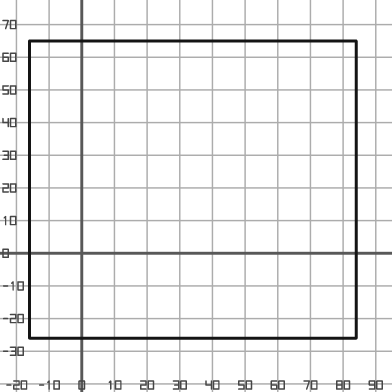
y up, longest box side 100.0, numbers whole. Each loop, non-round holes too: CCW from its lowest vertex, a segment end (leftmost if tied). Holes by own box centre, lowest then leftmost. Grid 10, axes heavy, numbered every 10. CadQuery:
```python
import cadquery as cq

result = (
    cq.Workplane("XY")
    .moveTo(-16.0, -26.0)
    .lineTo(84.0, -26.0)
    .lineTo(84.0, 65.0)
    .lineTo(-16.0, 65.0)
    .close()
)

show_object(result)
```